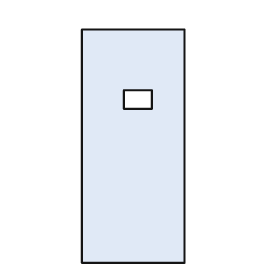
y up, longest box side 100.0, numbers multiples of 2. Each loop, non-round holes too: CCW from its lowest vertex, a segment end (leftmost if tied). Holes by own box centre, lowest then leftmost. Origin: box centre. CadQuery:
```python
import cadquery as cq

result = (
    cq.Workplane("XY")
    .moveTo(-22.0, -50.0)
    .lineTo(22.0, -50.0)
    .lineTo(22.0, 50.0)
    .lineTo(-22.0, 50.0)
    .close()
    .moveTo(-4.0, 16.0)
    .lineTo(8.0, 16.0)
    .lineTo(8.0, 24.0)
    .lineTo(-4.0, 24.0)
    .close()
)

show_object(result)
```